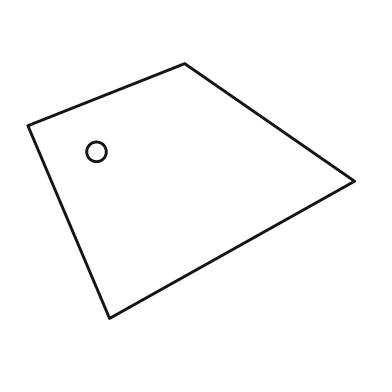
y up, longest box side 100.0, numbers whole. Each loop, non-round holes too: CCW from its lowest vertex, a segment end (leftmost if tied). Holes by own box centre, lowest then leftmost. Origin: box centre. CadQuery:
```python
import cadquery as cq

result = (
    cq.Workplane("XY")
    .moveTo(-25.0, -39.0)
    .lineTo(50.0, 3.0)
    .lineTo(-2.0, 39.0)
    .lineTo(-50.0, 20.0)
    .close()
    .moveTo(-29.0, 12.0)
    .circle(3.0)
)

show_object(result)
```